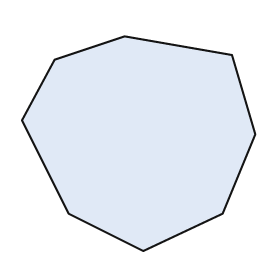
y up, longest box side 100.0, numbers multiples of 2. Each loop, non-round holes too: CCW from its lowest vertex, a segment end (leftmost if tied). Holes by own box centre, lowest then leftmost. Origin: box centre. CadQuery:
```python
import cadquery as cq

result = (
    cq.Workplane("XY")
    .moveTo(2.0, -46.0)
    .lineTo(36.0, -30.0)
    .lineTo(50.0, 4.0)
    .lineTo(40.0, 38.0)
    .lineTo(-6.0, 46.0)
    .lineTo(-36.0, 36.0)
    .lineTo(-50.0, 10.0)
    .lineTo(-30.0, -30.0)
    .close()
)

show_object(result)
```